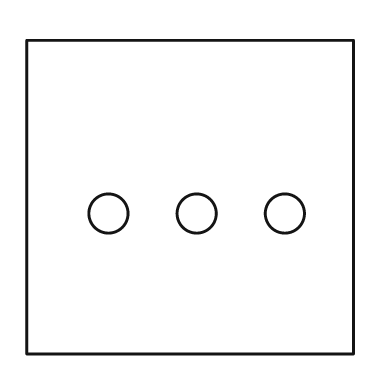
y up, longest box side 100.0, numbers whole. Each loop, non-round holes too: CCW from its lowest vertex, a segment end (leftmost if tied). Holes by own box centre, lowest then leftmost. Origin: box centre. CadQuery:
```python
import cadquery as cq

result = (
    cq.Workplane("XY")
    .moveTo(-50.0, -48.0)
    .lineTo(50.0, -48.0)
    .lineTo(50.0, 48.0)
    .lineTo(-50.0, 48.0)
    .close()
    .moveTo(-25.0, -5.0)
    .circle(6.0)
    .moveTo(2.0, -5.0)
    .circle(6.0)
    .moveTo(29.0, -5.0)
    .circle(6.0)
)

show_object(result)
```